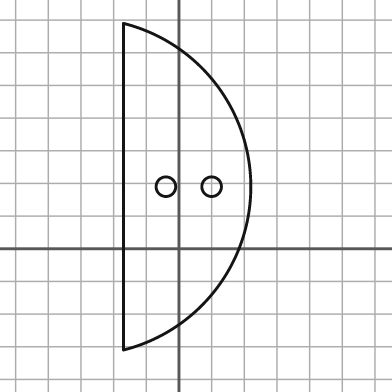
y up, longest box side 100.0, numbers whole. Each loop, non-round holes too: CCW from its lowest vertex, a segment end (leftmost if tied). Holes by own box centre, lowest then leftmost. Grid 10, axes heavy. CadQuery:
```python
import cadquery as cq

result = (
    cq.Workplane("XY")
    .moveTo(-17.0, -31.0)
    .threePointArc((22.0, 19.0), (-17.0, 69.0))
    .close()
    .moveTo(-4.0, 19.0)
    .circle(3.0)
    .moveTo(10.0, 19.0)
    .circle(3.0)
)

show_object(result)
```